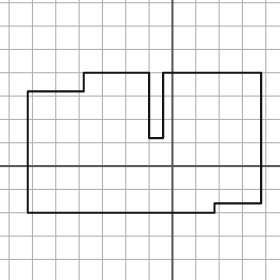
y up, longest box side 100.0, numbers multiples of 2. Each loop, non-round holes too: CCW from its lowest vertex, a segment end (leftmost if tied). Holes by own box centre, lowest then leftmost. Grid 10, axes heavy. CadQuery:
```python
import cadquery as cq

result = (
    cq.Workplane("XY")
    .moveTo(-62.0, -20.0)
    .lineTo(18.0, -20.0)
    .lineTo(18.0, -16.0)
    .lineTo(38.0, -16.0)
    .lineTo(38.0, 40.0)
    .lineTo(-4.0, 40.0)
    .lineTo(-4.0, 12.0)
    .lineTo(-10.0, 12.0)
    .lineTo(-10.0, 40.0)
    .lineTo(-38.0, 40.0)
    .lineTo(-38.0, 32.0)
    .lineTo(-62.0, 32.0)
    .close()
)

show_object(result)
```